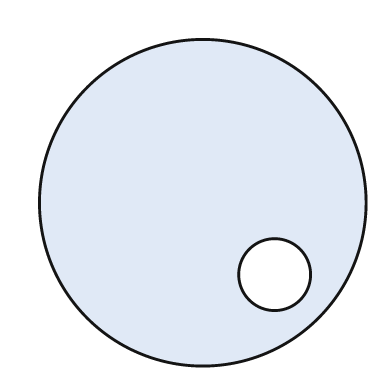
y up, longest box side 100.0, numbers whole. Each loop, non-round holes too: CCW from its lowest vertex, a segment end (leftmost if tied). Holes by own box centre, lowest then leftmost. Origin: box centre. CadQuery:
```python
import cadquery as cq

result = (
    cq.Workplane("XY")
    .moveTo(0.0, 0.0)
    .circle(50.0)
    .moveTo(22.0, -22.0)
    .circle(11.0)
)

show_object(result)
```